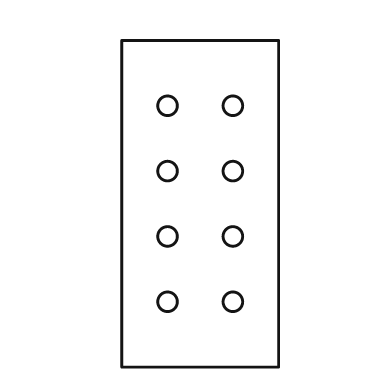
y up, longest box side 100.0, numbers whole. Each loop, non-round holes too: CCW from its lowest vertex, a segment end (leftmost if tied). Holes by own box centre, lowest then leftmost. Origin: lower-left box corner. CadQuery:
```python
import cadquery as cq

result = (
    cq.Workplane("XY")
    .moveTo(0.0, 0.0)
    .lineTo(48.0, 0.0)
    .lineTo(48.0, 100.0)
    .lineTo(0.0, 100.0)
    .close()
    .moveTo(14.0, 20.0)
    .circle(3.0)
    .moveTo(34.0, 20.0)
    .circle(3.0)
    .moveTo(14.0, 40.0)
    .circle(3.0)
    .moveTo(34.0, 40.0)
    .circle(3.0)
    .moveTo(14.0, 60.0)
    .circle(3.0)
    .moveTo(34.0, 60.0)
    .circle(3.0)
    .moveTo(14.0, 80.0)
    .circle(3.0)
    .moveTo(34.0, 80.0)
    .circle(3.0)
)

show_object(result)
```